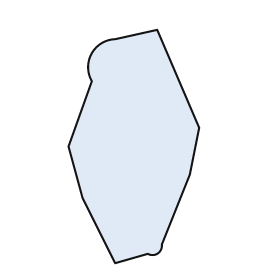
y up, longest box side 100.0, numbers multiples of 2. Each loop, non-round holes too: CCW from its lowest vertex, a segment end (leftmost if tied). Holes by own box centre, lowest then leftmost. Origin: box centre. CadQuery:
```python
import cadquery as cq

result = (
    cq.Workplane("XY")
    .moveTo(-8.0, -50.0)
    .lineTo(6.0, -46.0)
    .threePointArc((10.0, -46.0), (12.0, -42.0))
    .lineTo(24.0, -12.0)
    .lineTo(28.0, 8.0)
    .lineTo(10.0, 50.0)
    .lineTo(-8.0, 46.0)
    .threePointArc((-18.0, 40.0), (-18.0, 28.0))
    .lineTo(-28.0, 0.0)
    .lineTo(-22.0, -22.0)
    .close()
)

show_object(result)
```